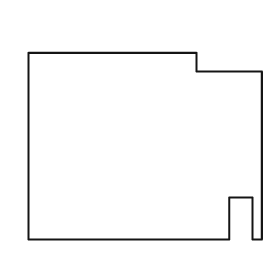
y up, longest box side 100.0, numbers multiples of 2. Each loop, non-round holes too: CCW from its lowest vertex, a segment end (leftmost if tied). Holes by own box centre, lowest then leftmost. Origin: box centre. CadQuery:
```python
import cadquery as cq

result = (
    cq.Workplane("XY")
    .moveTo(-50.0, -40.0)
    .lineTo(36.0, -40.0)
    .lineTo(36.0, -22.0)
    .lineTo(46.0, -22.0)
    .lineTo(46.0, -40.0)
    .lineTo(50.0, -40.0)
    .lineTo(50.0, 32.0)
    .lineTo(22.0, 32.0)
    .lineTo(22.0, 40.0)
    .lineTo(-50.0, 40.0)
    .close()
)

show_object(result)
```